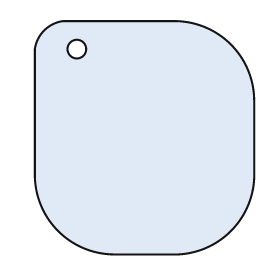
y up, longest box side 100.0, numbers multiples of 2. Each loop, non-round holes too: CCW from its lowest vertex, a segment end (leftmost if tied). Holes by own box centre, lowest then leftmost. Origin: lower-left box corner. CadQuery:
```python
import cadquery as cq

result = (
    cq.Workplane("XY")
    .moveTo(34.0, 0.0)
    .lineTo(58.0, 0.0)
    .threePointArc((84.0, 10.0), (94.0, 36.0))
    .lineTo(94.0, 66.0)
    .threePointArc((84.0, 90.0), (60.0, 100.0))
    .lineTo(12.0, 100.0)
    .threePointArc((4.0, 96.0), (0.0, 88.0))
    .lineTo(0.0, 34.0)
    .threePointArc((10.0, 10.0), (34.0, 0.0))
    .close()
    .moveTo(18.0, 88.0)
    .circle(4.0)
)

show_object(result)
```